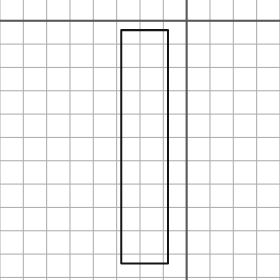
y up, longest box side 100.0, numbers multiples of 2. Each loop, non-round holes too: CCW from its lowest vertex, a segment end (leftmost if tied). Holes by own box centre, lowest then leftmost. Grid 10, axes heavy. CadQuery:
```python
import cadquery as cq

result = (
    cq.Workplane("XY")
    .moveTo(-28.0, -104.0)
    .lineTo(-8.0, -104.0)
    .lineTo(-8.0, -4.0)
    .lineTo(-28.0, -4.0)
    .close()
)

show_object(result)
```